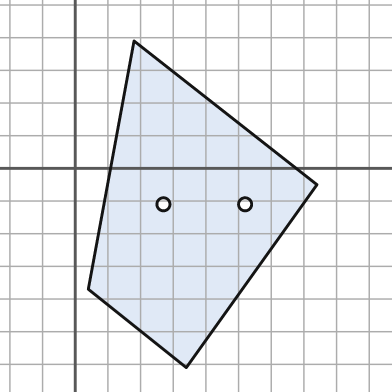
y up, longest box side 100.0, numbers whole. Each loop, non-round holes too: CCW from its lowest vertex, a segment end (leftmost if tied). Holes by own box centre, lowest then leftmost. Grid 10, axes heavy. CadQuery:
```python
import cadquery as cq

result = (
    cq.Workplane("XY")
    .moveTo(34.0, -61.0)
    .lineTo(74.0, -5.0)
    .lineTo(18.0, 39.0)
    .lineTo(4.0, -37.0)
    .close()
    .moveTo(27.0, -11.0)
    .circle(2.0)
    .moveTo(52.0, -11.0)
    .circle(2.0)
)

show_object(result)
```